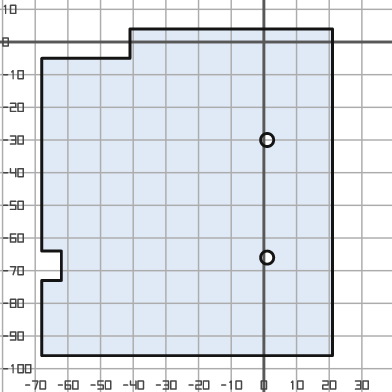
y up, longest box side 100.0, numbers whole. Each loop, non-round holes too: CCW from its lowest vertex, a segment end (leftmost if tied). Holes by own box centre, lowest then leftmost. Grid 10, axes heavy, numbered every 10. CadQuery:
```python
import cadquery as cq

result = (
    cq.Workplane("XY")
    .moveTo(-68.0, -96.0)
    .lineTo(21.0, -96.0)
    .lineTo(21.0, 4.0)
    .lineTo(-41.0, 4.0)
    .lineTo(-41.0, -5.0)
    .lineTo(-68.0, -5.0)
    .lineTo(-68.0, -64.0)
    .lineTo(-62.0, -64.0)
    .lineTo(-62.0, -73.0)
    .lineTo(-68.0, -73.0)
    .close()
    .moveTo(1.0, -66.0)
    .circle(2.0)
    .moveTo(1.0, -30.0)
    .circle(2.0)
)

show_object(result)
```